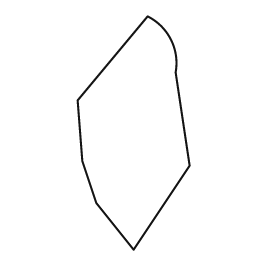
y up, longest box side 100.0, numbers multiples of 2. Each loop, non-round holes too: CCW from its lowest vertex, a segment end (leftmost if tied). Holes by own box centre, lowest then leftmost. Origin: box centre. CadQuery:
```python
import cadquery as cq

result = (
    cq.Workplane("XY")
    .moveTo(0.0, -50.0)
    .lineTo(24.0, -14.0)
    .lineTo(18.0, 26.0)
    .threePointArc((16.0, 40.0), (6.0, 50.0))
    .lineTo(-24.0, 14.0)
    .lineTo(-22.0, -12.0)
    .lineTo(-16.0, -30.0)
    .close()
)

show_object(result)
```